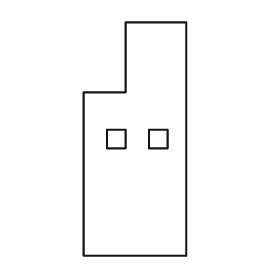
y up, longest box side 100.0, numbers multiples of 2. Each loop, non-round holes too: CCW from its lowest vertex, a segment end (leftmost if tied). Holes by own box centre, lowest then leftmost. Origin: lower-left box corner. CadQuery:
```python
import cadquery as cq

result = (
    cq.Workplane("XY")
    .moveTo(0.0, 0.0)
    .lineTo(44.0, 0.0)
    .lineTo(44.0, 100.0)
    .lineTo(18.0, 100.0)
    .lineTo(18.0, 70.0)
    .lineTo(0.0, 70.0)
    .close()
    .moveTo(10.0, 46.0)
    .lineTo(18.0, 46.0)
    .lineTo(18.0, 54.0)
    .lineTo(10.0, 54.0)
    .close()
    .moveTo(28.0, 46.0)
    .lineTo(36.0, 46.0)
    .lineTo(36.0, 54.0)
    .lineTo(28.0, 54.0)
    .close()
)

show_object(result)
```